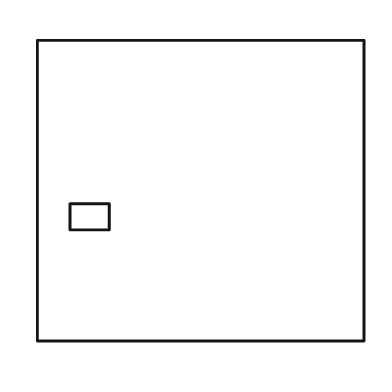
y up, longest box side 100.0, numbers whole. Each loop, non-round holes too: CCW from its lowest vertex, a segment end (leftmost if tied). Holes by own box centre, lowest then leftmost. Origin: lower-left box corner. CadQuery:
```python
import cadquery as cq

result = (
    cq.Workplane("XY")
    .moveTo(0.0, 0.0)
    .lineTo(100.0, 0.0)
    .lineTo(100.0, 92.0)
    .lineTo(0.0, 92.0)
    .close()
    .moveTo(10.0, 34.0)
    .lineTo(22.0, 34.0)
    .lineTo(22.0, 42.0)
    .lineTo(10.0, 42.0)
    .close()
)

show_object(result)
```